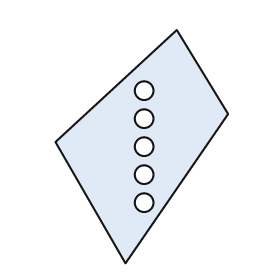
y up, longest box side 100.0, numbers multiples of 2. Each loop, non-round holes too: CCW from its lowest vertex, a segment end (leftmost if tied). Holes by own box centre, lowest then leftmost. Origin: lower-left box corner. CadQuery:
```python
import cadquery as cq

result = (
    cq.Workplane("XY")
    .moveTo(30.0, 0.0)
    .lineTo(74.0, 64.0)
    .lineTo(52.0, 100.0)
    .lineTo(0.0, 52.0)
    .close()
    .moveTo(38.0, 26.0)
    .circle(4.0)
    .moveTo(38.0, 38.0)
    .circle(4.0)
    .moveTo(38.0, 50.0)
    .circle(4.0)
    .moveTo(38.0, 62.0)
    .circle(4.0)
    .moveTo(38.0, 74.0)
    .circle(4.0)
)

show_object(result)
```